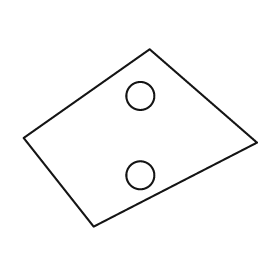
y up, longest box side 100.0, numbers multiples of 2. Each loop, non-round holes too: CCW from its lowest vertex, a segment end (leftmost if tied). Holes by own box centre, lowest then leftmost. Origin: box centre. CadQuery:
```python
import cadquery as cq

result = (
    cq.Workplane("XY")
    .moveTo(-20.0, -38.0)
    .lineTo(50.0, -2.0)
    .lineTo(4.0, 38.0)
    .lineTo(-50.0, 0.0)
    .close()
    .moveTo(0.0, -16.0)
    .circle(6.0)
    .moveTo(0.0, 18.0)
    .circle(6.0)
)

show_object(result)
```